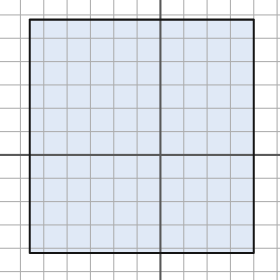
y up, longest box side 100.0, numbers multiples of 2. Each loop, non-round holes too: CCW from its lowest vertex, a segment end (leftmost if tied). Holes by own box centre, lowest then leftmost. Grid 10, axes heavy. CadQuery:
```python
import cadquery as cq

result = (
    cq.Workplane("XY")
    .moveTo(-56.0, -42.0)
    .lineTo(40.0, -42.0)
    .lineTo(40.0, 58.0)
    .lineTo(-56.0, 58.0)
    .close()
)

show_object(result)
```